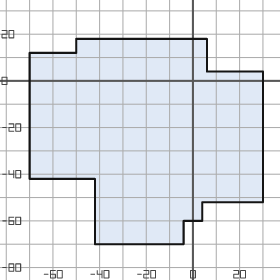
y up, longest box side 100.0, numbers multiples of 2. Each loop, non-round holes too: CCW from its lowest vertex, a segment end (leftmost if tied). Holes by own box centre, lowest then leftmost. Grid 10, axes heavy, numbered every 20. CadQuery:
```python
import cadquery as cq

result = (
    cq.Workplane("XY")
    .moveTo(-42.0, -70.0)
    .lineTo(-4.0, -70.0)
    .lineTo(-4.0, -60.0)
    .lineTo(4.0, -60.0)
    .lineTo(4.0, -52.0)
    .lineTo(30.0, -52.0)
    .lineTo(30.0, 4.0)
    .lineTo(6.0, 4.0)
    .lineTo(6.0, 18.0)
    .lineTo(-50.0, 18.0)
    .lineTo(-50.0, 12.0)
    .lineTo(-70.0, 12.0)
    .lineTo(-70.0, -42.0)
    .lineTo(-42.0, -42.0)
    .close()
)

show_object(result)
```